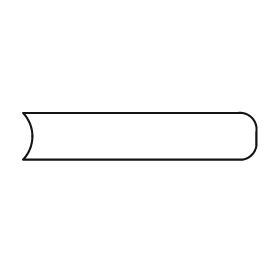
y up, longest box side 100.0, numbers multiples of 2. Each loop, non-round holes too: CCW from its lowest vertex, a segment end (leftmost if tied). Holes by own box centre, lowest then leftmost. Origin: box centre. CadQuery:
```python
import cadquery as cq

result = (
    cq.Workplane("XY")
    .moveTo(-50.0, -10.0)
    .lineTo(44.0, -10.0)
    .threePointArc((48.0, -8.0), (50.0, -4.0))
    .lineTo(50.0, 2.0)
    .threePointArc((48.0, 8.0), (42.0, 10.0))
    .lineTo(-50.0, 10.0)
    .threePointArc((-46.0, 0.0), (-50.0, -10.0))
    .close()
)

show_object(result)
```